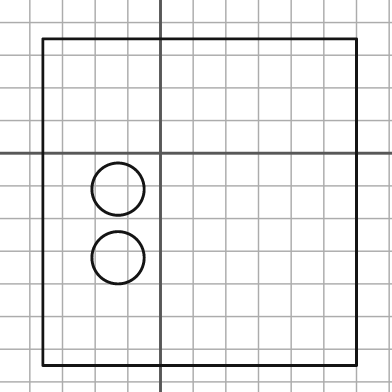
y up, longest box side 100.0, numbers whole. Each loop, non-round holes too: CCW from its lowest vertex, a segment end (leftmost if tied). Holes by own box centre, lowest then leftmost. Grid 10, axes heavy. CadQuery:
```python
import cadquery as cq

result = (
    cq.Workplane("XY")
    .moveTo(-36.0, -65.0)
    .lineTo(60.0, -65.0)
    .lineTo(60.0, 35.0)
    .lineTo(-36.0, 35.0)
    .close()
    .moveTo(-13.0, -32.0)
    .circle(8.0)
    .moveTo(-13.0, -11.0)
    .circle(8.0)
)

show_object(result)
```